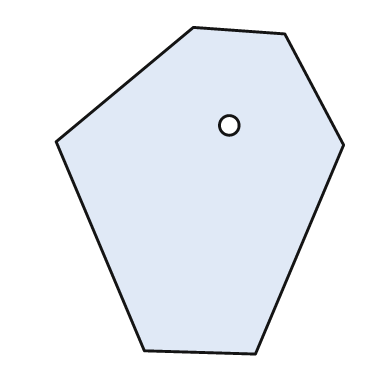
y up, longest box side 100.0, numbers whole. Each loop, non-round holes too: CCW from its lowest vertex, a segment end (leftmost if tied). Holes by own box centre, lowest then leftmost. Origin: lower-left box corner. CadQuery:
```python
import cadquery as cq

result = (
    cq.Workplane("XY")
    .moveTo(61.0, 0.0)
    .lineTo(88.0, 64.0)
    .lineTo(70.0, 98.0)
    .lineTo(42.0, 100.0)
    .lineTo(0.0, 65.0)
    .lineTo(27.0, 1.0)
    .close()
    .moveTo(53.0, 70.0)
    .circle(3.0)
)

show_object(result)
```